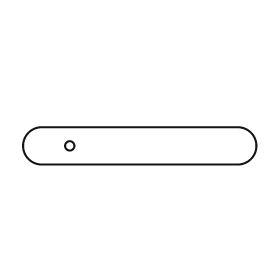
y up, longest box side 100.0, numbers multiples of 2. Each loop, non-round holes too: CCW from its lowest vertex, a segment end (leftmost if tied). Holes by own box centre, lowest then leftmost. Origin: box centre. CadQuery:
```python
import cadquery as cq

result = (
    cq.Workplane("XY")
    .moveTo(-42.0, -8.0)
    .lineTo(42.0, -8.0)
    .threePointArc((50.0, 0.0), (42.0, 8.0))
    .lineTo(-42.0, 8.0)
    .threePointArc((-50.0, 0.0), (-42.0, -8.0))
    .close()
    .moveTo(-30.0, 0.0)
    .circle(2.0)
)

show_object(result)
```